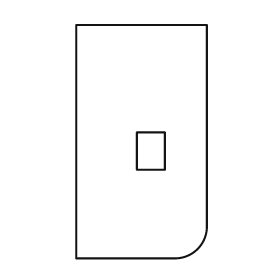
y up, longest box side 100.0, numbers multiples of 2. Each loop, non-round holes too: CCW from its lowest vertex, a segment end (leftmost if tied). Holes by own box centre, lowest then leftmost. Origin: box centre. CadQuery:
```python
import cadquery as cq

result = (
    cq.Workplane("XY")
    .moveTo(-28.0, -50.0)
    .lineTo(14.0, -50.0)
    .threePointArc((24.0, -46.0), (28.0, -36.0))
    .lineTo(28.0, 50.0)
    .lineTo(-28.0, 50.0)
    .close()
    .moveTo(-2.0, -12.0)
    .lineTo(10.0, -12.0)
    .lineTo(10.0, 4.0)
    .lineTo(-2.0, 4.0)
    .close()
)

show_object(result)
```